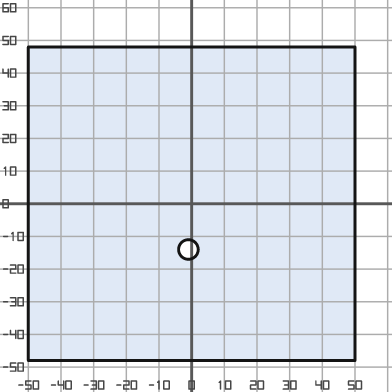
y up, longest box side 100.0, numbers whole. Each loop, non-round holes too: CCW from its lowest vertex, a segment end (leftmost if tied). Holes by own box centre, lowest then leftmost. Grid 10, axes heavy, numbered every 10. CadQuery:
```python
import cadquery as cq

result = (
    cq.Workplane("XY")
    .moveTo(-50.0, -48.0)
    .lineTo(50.0, -48.0)
    .lineTo(50.0, 48.0)
    .lineTo(-50.0, 48.0)
    .close()
    .moveTo(-1.0, -14.0)
    .circle(3.0)
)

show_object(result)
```